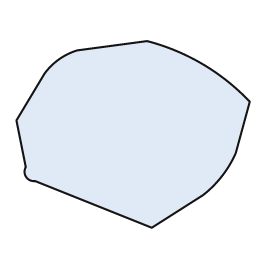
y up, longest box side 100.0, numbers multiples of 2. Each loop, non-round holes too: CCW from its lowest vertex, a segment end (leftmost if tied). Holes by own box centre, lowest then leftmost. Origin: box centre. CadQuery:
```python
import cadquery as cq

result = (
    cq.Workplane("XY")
    .moveTo(8.0, -40.0)
    .lineTo(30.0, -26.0)
    .threePointArc((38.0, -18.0), (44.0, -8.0))
    .lineTo(50.0, 14.0)
    .threePointArc((30.0, 30.0), (6.0, 40.0))
    .lineTo(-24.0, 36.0)
    .threePointArc((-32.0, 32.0), (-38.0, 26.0))
    .lineTo(-50.0, 6.0)
    .lineTo(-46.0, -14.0)
    .threePointArc((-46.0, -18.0), (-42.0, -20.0))
    .close()
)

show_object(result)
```